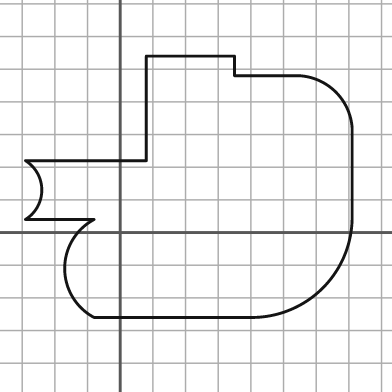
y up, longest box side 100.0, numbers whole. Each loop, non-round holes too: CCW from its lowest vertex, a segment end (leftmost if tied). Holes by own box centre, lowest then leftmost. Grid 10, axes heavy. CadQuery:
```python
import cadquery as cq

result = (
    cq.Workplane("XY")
    .moveTo(-8.0, -26.0)
    .lineTo(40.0, -26.0)
    .threePointArc((62.0, -17.0), (71.0, 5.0))
    .lineTo(71.0, 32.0)
    .threePointArc((66.0, 43.0), (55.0, 48.0))
    .lineTo(35.0, 48.0)
    .lineTo(35.0, 54.0)
    .lineTo(8.0, 54.0)
    .lineTo(8.0, 22.0)
    .lineTo(-29.0, 22.0)
    .threePointArc((-24.0, 13.0), (-29.0, 4.0))
    .lineTo(-8.0, 4.0)
    .threePointArc((-17.0, -11.0), (-8.0, -26.0))
    .close()
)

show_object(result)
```